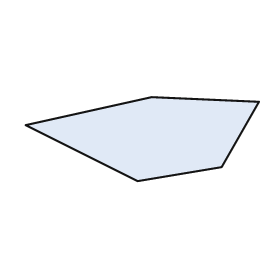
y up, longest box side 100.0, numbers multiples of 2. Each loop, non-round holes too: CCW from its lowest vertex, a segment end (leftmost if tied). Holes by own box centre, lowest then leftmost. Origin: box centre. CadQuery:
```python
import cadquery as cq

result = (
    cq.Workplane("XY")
    .moveTo(-2.0, -18.0)
    .lineTo(34.0, -12.0)
    .lineTo(50.0, 16.0)
    .lineTo(4.0, 18.0)
    .lineTo(-50.0, 6.0)
    .close()
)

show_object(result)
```